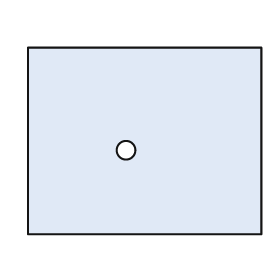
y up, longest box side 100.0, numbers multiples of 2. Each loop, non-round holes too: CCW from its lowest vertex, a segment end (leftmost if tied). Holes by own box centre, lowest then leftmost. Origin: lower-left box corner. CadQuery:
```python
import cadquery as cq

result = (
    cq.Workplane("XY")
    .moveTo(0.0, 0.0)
    .lineTo(100.0, 0.0)
    .lineTo(100.0, 80.0)
    .lineTo(0.0, 80.0)
    .close()
    .moveTo(42.0, 36.0)
    .circle(4.0)
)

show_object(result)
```